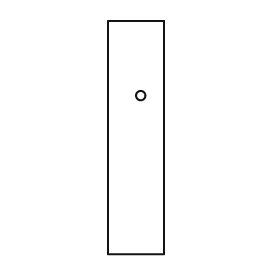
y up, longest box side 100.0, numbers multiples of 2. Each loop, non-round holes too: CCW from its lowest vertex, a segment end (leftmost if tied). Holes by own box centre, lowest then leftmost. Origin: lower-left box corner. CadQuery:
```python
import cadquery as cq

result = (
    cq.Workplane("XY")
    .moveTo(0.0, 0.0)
    .lineTo(24.0, 0.0)
    .lineTo(24.0, 100.0)
    .lineTo(0.0, 100.0)
    .close()
    .moveTo(14.0, 68.0)
    .circle(2.0)
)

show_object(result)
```